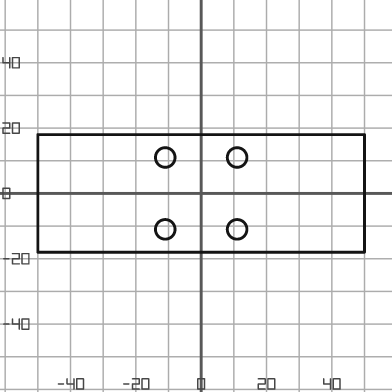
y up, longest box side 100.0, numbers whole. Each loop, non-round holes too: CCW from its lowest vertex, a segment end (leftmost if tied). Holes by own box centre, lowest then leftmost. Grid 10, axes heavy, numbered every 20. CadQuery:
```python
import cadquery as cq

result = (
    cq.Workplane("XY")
    .moveTo(-50.0, -18.0)
    .lineTo(50.0, -18.0)
    .lineTo(50.0, 18.0)
    .lineTo(-50.0, 18.0)
    .close()
    .moveTo(-11.0, -11.0)
    .circle(3.0)
    .moveTo(11.0, -11.0)
    .circle(3.0)
    .moveTo(-11.0, 11.0)
    .circle(3.0)
    .moveTo(11.0, 11.0)
    .circle(3.0)
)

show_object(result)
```